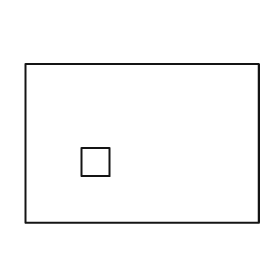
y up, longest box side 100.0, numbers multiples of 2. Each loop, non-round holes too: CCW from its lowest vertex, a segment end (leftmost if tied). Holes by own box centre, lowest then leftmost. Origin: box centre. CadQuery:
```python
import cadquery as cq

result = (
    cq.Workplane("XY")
    .moveTo(-50.0, -34.0)
    .lineTo(50.0, -34.0)
    .lineTo(50.0, 34.0)
    .lineTo(-50.0, 34.0)
    .close()
    .moveTo(-26.0, -14.0)
    .lineTo(-14.0, -14.0)
    .lineTo(-14.0, -2.0)
    .lineTo(-26.0, -2.0)
    .close()
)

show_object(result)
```